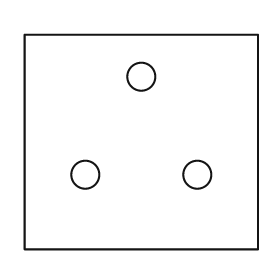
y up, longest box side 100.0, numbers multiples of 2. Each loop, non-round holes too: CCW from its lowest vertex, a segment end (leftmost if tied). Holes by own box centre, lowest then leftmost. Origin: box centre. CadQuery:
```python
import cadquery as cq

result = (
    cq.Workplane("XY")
    .moveTo(-50.0, -46.0)
    .lineTo(50.0, -46.0)
    .lineTo(50.0, 46.0)
    .lineTo(-50.0, 46.0)
    .close()
    .moveTo(-24.0, -14.0)
    .circle(6.0)
    .moveTo(24.0, -14.0)
    .circle(6.0)
    .moveTo(0.0, 28.0)
    .circle(6.0)
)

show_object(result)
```